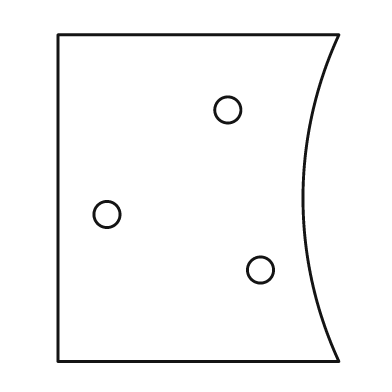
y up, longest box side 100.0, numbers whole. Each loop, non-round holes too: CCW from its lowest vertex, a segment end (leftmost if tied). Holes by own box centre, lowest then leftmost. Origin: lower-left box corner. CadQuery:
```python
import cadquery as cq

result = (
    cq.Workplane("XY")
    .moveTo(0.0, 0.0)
    .lineTo(86.0, 0.0)
    .threePointArc((75.0, 50.0), (86.0, 100.0))
    .lineTo(0.0, 100.0)
    .close()
    .moveTo(62.0, 28.0)
    .circle(4.0)
    .moveTo(15.0, 45.0)
    .circle(4.0)
    .moveTo(52.0, 77.0)
    .circle(4.0)
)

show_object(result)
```